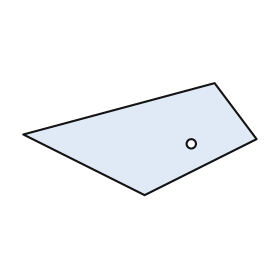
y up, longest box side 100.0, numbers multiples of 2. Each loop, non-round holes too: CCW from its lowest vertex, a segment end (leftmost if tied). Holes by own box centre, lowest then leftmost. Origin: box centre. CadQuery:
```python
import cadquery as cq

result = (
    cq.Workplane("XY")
    .moveTo(2.0, -24.0)
    .lineTo(50.0, 0.0)
    .lineTo(32.0, 24.0)
    .lineTo(-50.0, 2.0)
    .close()
    .moveTo(22.0, -2.0)
    .circle(2.0)
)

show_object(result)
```